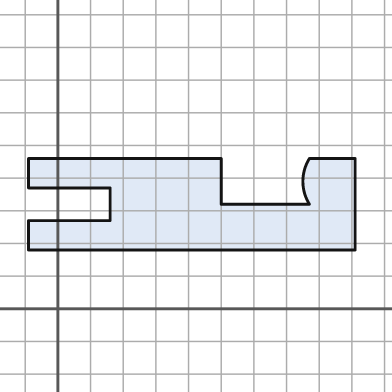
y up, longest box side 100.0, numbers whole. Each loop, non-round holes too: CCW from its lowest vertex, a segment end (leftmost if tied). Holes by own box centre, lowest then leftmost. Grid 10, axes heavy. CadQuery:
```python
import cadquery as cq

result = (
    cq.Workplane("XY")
    .moveTo(-9.0, 18.0)
    .lineTo(91.0, 18.0)
    .lineTo(91.0, 46.0)
    .lineTo(77.0, 46.0)
    .threePointArc((75.0, 39.0), (77.0, 32.0))
    .lineTo(50.0, 32.0)
    .lineTo(50.0, 46.0)
    .lineTo(-9.0, 46.0)
    .lineTo(-9.0, 37.0)
    .lineTo(16.0, 37.0)
    .lineTo(16.0, 27.0)
    .lineTo(-9.0, 27.0)
    .close()
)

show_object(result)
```